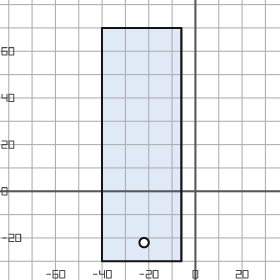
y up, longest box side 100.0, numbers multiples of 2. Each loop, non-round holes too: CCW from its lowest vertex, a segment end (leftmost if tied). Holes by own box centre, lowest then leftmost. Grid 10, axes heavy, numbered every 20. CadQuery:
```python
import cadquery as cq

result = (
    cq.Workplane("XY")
    .moveTo(-40.0, -30.0)
    .lineTo(-6.0, -30.0)
    .lineTo(-6.0, 70.0)
    .lineTo(-40.0, 70.0)
    .close()
    .moveTo(-22.0, -22.0)
    .circle(2.0)
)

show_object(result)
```